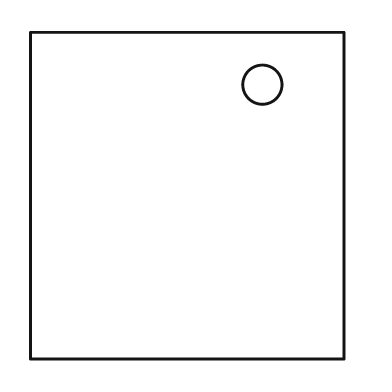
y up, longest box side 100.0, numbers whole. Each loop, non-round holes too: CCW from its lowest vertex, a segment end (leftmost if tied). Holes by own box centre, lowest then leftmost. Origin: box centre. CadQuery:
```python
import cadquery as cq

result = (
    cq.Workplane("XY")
    .moveTo(-48.0, -50.0)
    .lineTo(48.0, -50.0)
    .lineTo(48.0, 50.0)
    .lineTo(-48.0, 50.0)
    .close()
    .moveTo(23.0, 34.0)
    .circle(6.0)
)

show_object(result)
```